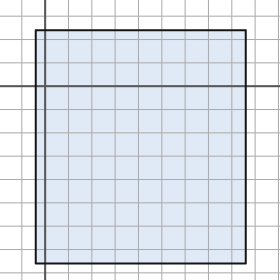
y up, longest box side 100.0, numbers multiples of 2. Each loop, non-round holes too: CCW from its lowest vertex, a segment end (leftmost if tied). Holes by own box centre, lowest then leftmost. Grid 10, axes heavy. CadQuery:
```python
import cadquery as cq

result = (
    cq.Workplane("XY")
    .moveTo(-4.0, -76.0)
    .lineTo(86.0, -76.0)
    .lineTo(86.0, 24.0)
    .lineTo(-4.0, 24.0)
    .close()
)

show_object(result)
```